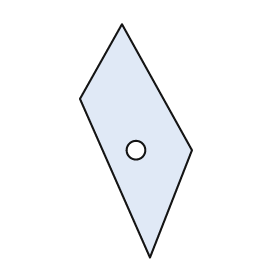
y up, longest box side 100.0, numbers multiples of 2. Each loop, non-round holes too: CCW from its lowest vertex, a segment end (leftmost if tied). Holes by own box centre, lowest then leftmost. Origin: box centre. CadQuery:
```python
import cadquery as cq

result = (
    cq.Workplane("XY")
    .moveTo(6.0, -50.0)
    .lineTo(24.0, -4.0)
    .lineTo(-6.0, 50.0)
    .lineTo(-24.0, 18.0)
    .close()
    .moveTo(0.0, -4.0)
    .circle(4.0)
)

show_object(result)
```